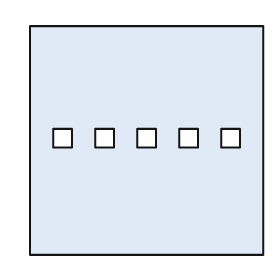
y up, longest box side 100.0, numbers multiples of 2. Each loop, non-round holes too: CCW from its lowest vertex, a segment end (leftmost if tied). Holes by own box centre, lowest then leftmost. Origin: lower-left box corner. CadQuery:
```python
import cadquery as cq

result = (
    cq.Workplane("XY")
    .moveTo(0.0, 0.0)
    .lineTo(100.0, 0.0)
    .lineTo(100.0, 98.0)
    .lineTo(0.0, 98.0)
    .close()
    .moveTo(10.0, 46.0)
    .lineTo(18.0, 46.0)
    .lineTo(18.0, 54.0)
    .lineTo(10.0, 54.0)
    .close()
    .moveTo(28.0, 46.0)
    .lineTo(36.0, 46.0)
    .lineTo(36.0, 54.0)
    .lineTo(28.0, 54.0)
    .close()
    .moveTo(46.0, 46.0)
    .lineTo(54.0, 46.0)
    .lineTo(54.0, 54.0)
    .lineTo(46.0, 54.0)
    .close()
    .moveTo(64.0, 46.0)
    .lineTo(72.0, 46.0)
    .lineTo(72.0, 54.0)
    .lineTo(64.0, 54.0)
    .close()
    .moveTo(82.0, 46.0)
    .lineTo(90.0, 46.0)
    .lineTo(90.0, 54.0)
    .lineTo(82.0, 54.0)
    .close()
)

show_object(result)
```